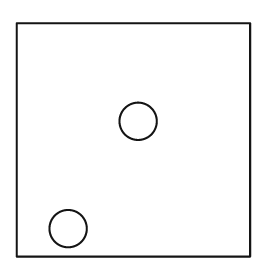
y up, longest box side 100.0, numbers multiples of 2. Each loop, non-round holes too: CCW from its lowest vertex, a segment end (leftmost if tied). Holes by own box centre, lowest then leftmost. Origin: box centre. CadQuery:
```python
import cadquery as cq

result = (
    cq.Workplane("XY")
    .moveTo(-50.0, -50.0)
    .lineTo(50.0, -50.0)
    .lineTo(50.0, 50.0)
    .lineTo(-50.0, 50.0)
    .close()
    .moveTo(-28.0, -38.0)
    .circle(8.0)
    .moveTo(2.0, 8.0)
    .circle(8.0)
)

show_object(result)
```